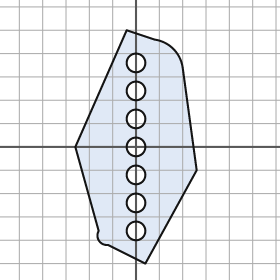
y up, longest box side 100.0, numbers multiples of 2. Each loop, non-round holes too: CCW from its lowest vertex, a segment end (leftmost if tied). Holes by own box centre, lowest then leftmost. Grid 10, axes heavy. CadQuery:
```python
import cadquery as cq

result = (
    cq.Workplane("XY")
    .moveTo(4.0, -50.0)
    .lineTo(26.0, -10.0)
    .lineTo(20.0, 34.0)
    .threePointArc((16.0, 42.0), (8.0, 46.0))
    .lineTo(-4.0, 50.0)
    .lineTo(-26.0, 0.0)
    .lineTo(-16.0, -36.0)
    .threePointArc((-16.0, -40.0), (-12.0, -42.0))
    .close()
    .moveTo(0.0, -36.0)
    .circle(4.0)
    .moveTo(0.0, -24.0)
    .circle(4.0)
    .moveTo(0.0, -12.0)
    .circle(4.0)
    .moveTo(0.0, 0.0)
    .circle(4.0)
    .moveTo(0.0, 12.0)
    .circle(4.0)
    .moveTo(0.0, 24.0)
    .circle(4.0)
    .moveTo(0.0, 36.0)
    .circle(4.0)
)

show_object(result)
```